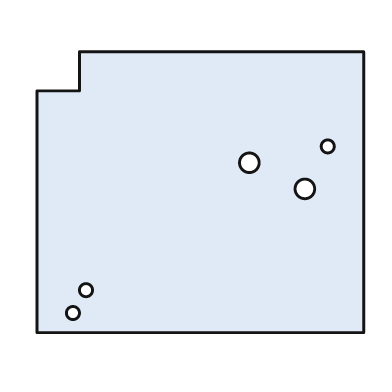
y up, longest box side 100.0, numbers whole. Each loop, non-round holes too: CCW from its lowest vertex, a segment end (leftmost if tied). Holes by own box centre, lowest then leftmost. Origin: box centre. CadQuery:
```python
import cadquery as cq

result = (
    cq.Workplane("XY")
    .moveTo(-50.0, -43.0)
    .lineTo(50.0, -43.0)
    .lineTo(50.0, 43.0)
    .lineTo(-37.0, 43.0)
    .lineTo(-37.0, 31.0)
    .lineTo(-50.0, 31.0)
    .close()
    .moveTo(-39.0, -37.0)
    .circle(2.0)
    .moveTo(-35.0, -30.0)
    .circle(2.0)
    .moveTo(32.0, 1.0)
    .circle(3.0)
    .moveTo(15.0, 9.0)
    .circle(3.0)
    .moveTo(39.0, 14.0)
    .circle(2.0)
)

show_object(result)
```